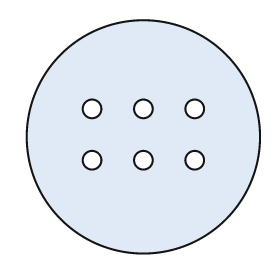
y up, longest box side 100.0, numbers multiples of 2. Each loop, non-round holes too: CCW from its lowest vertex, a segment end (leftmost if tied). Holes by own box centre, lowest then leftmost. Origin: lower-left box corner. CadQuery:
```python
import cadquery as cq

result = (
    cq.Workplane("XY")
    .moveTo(50.0, 50.0)
    .circle(50.0)
    .moveTo(28.0, 40.0)
    .circle(4.0)
    .moveTo(50.0, 40.0)
    .circle(4.0)
    .moveTo(72.0, 40.0)
    .circle(4.0)
    .moveTo(28.0, 62.0)
    .circle(4.0)
    .moveTo(50.0, 62.0)
    .circle(4.0)
    .moveTo(72.0, 62.0)
    .circle(4.0)
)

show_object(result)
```